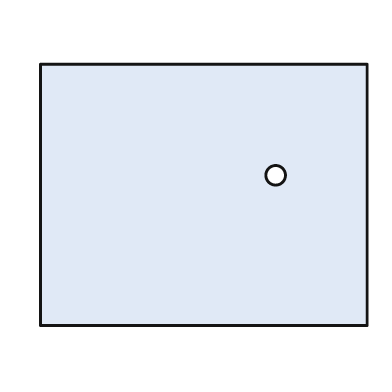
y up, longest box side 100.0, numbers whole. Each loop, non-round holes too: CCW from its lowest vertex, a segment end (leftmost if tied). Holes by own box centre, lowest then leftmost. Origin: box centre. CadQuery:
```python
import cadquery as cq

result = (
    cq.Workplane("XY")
    .moveTo(-50.0, -40.0)
    .lineTo(50.0, -40.0)
    .lineTo(50.0, 40.0)
    .lineTo(-50.0, 40.0)
    .close()
    .moveTo(22.0, 6.0)
    .circle(3.0)
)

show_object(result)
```